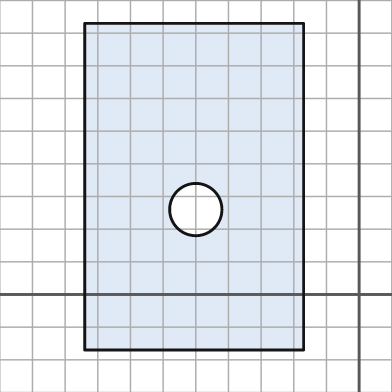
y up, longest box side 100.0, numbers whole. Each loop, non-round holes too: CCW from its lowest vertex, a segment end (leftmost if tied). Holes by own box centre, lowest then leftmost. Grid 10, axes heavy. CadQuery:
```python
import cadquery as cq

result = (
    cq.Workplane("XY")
    .moveTo(-84.0, -17.0)
    .lineTo(-17.0, -17.0)
    .lineTo(-17.0, 83.0)
    .lineTo(-84.0, 83.0)
    .close()
    .moveTo(-50.0, 26.0)
    .circle(8.0)
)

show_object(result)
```